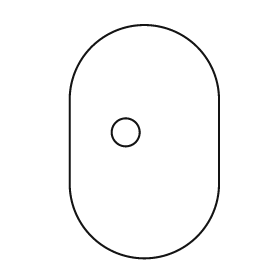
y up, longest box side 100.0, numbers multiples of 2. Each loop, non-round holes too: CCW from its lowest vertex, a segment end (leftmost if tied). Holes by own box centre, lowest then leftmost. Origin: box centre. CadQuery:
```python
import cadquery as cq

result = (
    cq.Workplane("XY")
    .moveTo(-32.0, -18.0)
    .threePointArc((0.0, -50.0), (32.0, -18.0))
    .lineTo(32.0, 18.0)
    .threePointArc((0.0, 50.0), (-32.0, 18.0))
    .close()
    .moveTo(-8.0, 4.0)
    .circle(6.0)
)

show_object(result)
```